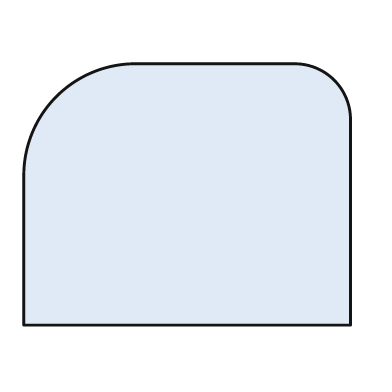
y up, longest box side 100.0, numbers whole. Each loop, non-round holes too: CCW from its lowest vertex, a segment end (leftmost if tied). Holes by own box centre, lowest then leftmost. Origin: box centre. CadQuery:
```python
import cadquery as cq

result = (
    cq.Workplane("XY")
    .moveTo(-50.0, -40.0)
    .lineTo(50.0, -40.0)
    .lineTo(50.0, 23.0)
    .threePointArc((45.0, 35.0), (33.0, 40.0))
    .lineTo(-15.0, 40.0)
    .threePointArc((-40.0, 30.0), (-50.0, 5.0))
    .close()
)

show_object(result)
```